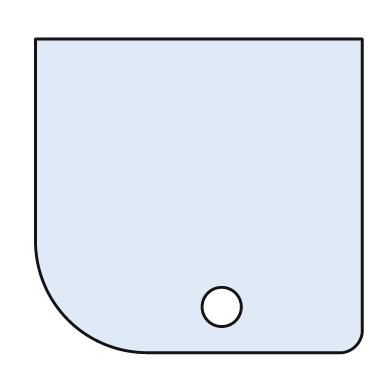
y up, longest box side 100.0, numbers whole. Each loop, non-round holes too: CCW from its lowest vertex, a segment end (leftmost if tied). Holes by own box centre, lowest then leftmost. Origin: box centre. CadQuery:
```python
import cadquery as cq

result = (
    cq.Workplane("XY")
    .moveTo(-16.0, -48.0)
    .lineTo(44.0, -48.0)
    .threePointArc((48.0, -46.0), (50.0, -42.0))
    .lineTo(50.0, 48.0)
    .lineTo(-50.0, 48.0)
    .lineTo(-50.0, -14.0)
    .threePointArc((-40.0, -38.0), (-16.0, -48.0))
    .close()
    .moveTo(7.0, -34.0)
    .circle(6.0)
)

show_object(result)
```